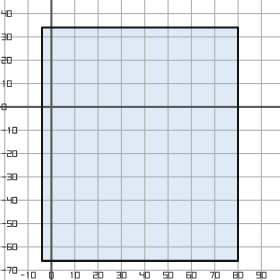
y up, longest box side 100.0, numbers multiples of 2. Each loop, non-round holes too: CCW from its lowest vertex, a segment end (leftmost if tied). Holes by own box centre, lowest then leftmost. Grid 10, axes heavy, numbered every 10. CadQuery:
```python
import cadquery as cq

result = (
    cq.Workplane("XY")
    .moveTo(-4.0, -66.0)
    .lineTo(80.0, -66.0)
    .lineTo(80.0, 34.0)
    .lineTo(-4.0, 34.0)
    .close()
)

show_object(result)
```